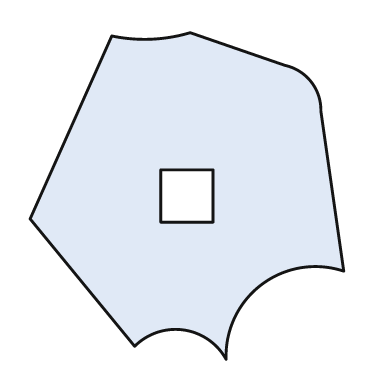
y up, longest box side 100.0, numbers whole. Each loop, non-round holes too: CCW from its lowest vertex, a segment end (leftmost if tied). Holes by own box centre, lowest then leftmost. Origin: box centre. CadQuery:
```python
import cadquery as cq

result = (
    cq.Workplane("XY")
    .moveTo(12.0, -50.0)
    .threePointArc((23.0, -27.0), (48.0, -23.0))
    .lineTo(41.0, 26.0)
    .threePointArc((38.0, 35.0), (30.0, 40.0))
    .lineTo(1.0, 50.0)
    .threePointArc((-11.0, 48.0), (-23.0, 49.0))
    .lineTo(-48.0, -7.0)
    .lineTo(-16.0, -46.0)
    .threePointArc((-1.0, -41.0), (12.0, -50.0))
    .close()
    .moveTo(-8.0, -8.0)
    .lineTo(8.0, -8.0)
    .lineTo(8.0, 8.0)
    .lineTo(-8.0, 8.0)
    .close()
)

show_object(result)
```